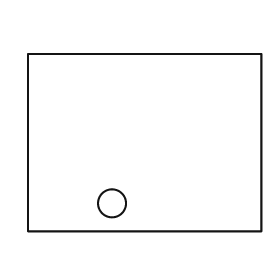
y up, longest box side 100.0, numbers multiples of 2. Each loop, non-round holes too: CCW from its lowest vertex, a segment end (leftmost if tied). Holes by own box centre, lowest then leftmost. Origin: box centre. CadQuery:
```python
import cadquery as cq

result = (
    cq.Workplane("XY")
    .moveTo(-50.0, -38.0)
    .lineTo(50.0, -38.0)
    .lineTo(50.0, 38.0)
    .lineTo(-50.0, 38.0)
    .close()
    .moveTo(-14.0, -26.0)
    .circle(6.0)
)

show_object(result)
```